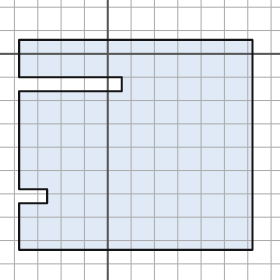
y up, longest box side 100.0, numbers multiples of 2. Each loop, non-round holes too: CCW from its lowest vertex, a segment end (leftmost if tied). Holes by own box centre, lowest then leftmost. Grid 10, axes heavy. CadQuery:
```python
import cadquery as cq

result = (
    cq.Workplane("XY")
    .moveTo(-38.0, -84.0)
    .lineTo(62.0, -84.0)
    .lineTo(62.0, 6.0)
    .lineTo(-38.0, 6.0)
    .lineTo(-38.0, -10.0)
    .lineTo(6.0, -10.0)
    .lineTo(6.0, -16.0)
    .lineTo(-38.0, -16.0)
    .lineTo(-38.0, -58.0)
    .lineTo(-26.0, -58.0)
    .lineTo(-26.0, -64.0)
    .lineTo(-38.0, -64.0)
    .close()
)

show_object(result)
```